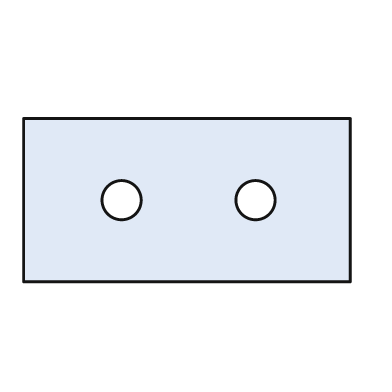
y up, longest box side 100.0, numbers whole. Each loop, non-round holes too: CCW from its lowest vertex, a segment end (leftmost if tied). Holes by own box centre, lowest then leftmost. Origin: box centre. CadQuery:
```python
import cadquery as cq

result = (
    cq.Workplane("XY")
    .moveTo(-50.0, -25.0)
    .lineTo(50.0, -25.0)
    .lineTo(50.0, 25.0)
    .lineTo(-50.0, 25.0)
    .close()
    .moveTo(-20.0, 0.0)
    .circle(6.0)
    .moveTo(21.0, 0.0)
    .circle(6.0)
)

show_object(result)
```